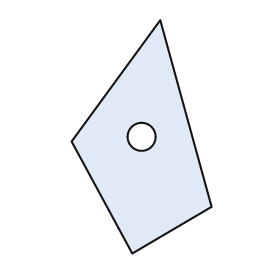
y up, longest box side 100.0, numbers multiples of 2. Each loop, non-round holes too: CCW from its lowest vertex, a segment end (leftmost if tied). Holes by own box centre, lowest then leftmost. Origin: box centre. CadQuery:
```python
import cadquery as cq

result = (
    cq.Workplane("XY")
    .moveTo(-4.0, -50.0)
    .lineTo(30.0, -30.0)
    .lineTo(8.0, 50.0)
    .lineTo(-30.0, -2.0)
    .close()
    .moveTo(0.0, 0.0)
    .circle(6.0)
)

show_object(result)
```